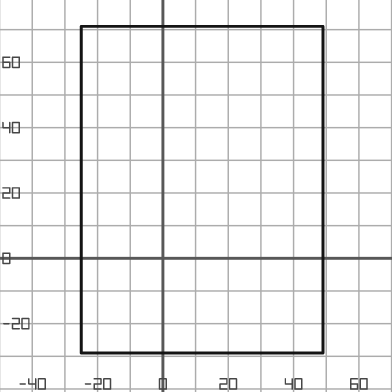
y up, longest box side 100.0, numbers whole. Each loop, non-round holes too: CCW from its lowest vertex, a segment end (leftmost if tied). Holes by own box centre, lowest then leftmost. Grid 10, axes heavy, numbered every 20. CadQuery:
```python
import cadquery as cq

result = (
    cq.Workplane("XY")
    .moveTo(-25.0, -29.0)
    .lineTo(49.0, -29.0)
    .lineTo(49.0, 71.0)
    .lineTo(-25.0, 71.0)
    .close()
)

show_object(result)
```